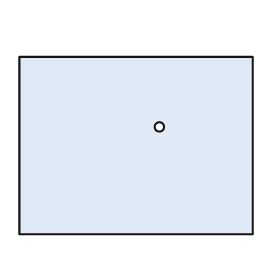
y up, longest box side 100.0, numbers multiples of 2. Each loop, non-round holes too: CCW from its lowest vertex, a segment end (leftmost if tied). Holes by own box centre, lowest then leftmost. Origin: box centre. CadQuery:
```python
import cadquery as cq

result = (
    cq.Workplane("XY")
    .moveTo(-50.0, -38.0)
    .lineTo(50.0, -38.0)
    .lineTo(50.0, 38.0)
    .lineTo(-50.0, 38.0)
    .close()
    .moveTo(10.0, 8.0)
    .circle(2.0)
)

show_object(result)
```